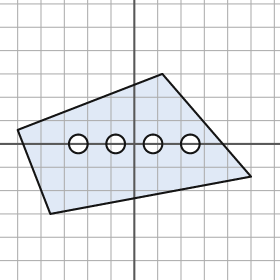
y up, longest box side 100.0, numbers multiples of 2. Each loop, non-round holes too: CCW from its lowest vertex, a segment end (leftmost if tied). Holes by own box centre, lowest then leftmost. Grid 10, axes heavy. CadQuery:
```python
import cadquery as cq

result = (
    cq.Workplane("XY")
    .moveTo(-36.0, -30.0)
    .lineTo(50.0, -14.0)
    .lineTo(12.0, 30.0)
    .lineTo(-50.0, 6.0)
    .close()
    .moveTo(-24.0, 0.0)
    .circle(4.0)
    .moveTo(-8.0, 0.0)
    .circle(4.0)
    .moveTo(8.0, 0.0)
    .circle(4.0)
    .moveTo(24.0, 0.0)
    .circle(4.0)
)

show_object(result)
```